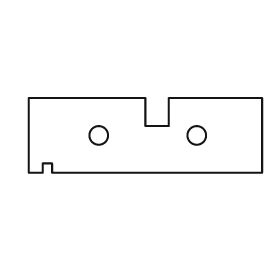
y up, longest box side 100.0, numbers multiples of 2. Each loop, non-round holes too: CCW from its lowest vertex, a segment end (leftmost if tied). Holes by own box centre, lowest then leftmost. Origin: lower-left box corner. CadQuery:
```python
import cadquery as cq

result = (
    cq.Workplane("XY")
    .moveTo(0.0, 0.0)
    .lineTo(6.0, 0.0)
    .lineTo(6.0, 4.0)
    .lineTo(10.0, 4.0)
    .lineTo(10.0, 0.0)
    .lineTo(100.0, 0.0)
    .lineTo(100.0, 32.0)
    .lineTo(60.0, 32.0)
    .lineTo(60.0, 20.0)
    .lineTo(50.0, 20.0)
    .lineTo(50.0, 32.0)
    .lineTo(0.0, 32.0)
    .close()
    .moveTo(30.0, 16.0)
    .circle(4.0)
    .moveTo(72.0, 16.0)
    .circle(4.0)
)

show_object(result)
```